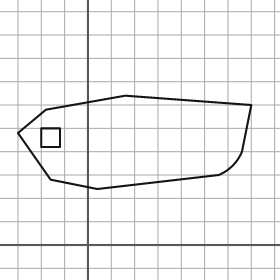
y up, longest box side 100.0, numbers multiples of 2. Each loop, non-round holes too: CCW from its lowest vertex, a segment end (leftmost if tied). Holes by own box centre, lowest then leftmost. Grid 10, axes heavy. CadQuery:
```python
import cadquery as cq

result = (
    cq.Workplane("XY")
    .moveTo(4.0, 24.0)
    .lineTo(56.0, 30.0)
    .threePointArc((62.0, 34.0), (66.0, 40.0))
    .lineTo(70.0, 60.0)
    .lineTo(16.0, 64.0)
    .lineTo(-18.0, 58.0)
    .lineTo(-30.0, 48.0)
    .lineTo(-16.0, 28.0)
    .close()
    .moveTo(-20.0, 42.0)
    .lineTo(-12.0, 42.0)
    .lineTo(-12.0, 50.0)
    .lineTo(-20.0, 50.0)
    .close()
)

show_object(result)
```